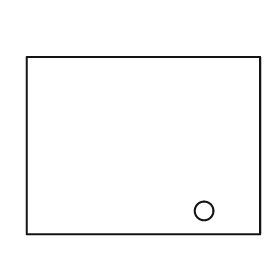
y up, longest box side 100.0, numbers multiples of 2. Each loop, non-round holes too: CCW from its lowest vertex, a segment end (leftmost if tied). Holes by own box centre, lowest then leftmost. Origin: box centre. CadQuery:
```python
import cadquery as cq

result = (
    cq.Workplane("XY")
    .moveTo(-50.0, -38.0)
    .lineTo(50.0, -38.0)
    .lineTo(50.0, 38.0)
    .lineTo(-50.0, 38.0)
    .close()
    .moveTo(26.0, -28.0)
    .circle(4.0)
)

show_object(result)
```